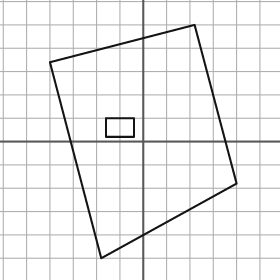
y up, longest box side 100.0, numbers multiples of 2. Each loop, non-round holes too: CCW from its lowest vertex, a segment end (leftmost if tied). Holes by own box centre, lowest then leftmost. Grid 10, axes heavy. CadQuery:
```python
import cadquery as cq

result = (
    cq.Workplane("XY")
    .moveTo(-18.0, -50.0)
    .lineTo(40.0, -18.0)
    .lineTo(22.0, 50.0)
    .lineTo(-40.0, 34.0)
    .close()
    .moveTo(-16.0, 2.0)
    .lineTo(-4.0, 2.0)
    .lineTo(-4.0, 10.0)
    .lineTo(-16.0, 10.0)
    .close()
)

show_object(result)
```